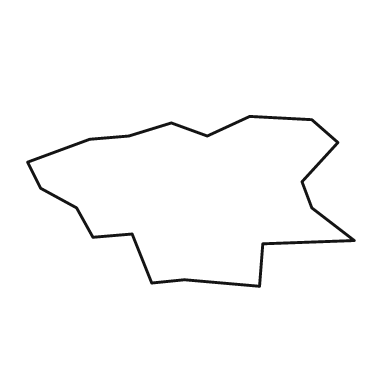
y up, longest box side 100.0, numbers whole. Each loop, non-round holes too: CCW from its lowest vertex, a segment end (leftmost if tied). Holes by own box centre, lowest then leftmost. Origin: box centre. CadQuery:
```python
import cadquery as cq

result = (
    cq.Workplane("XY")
    .moveTo(21.0, -26.0)
    .lineTo(22.0, -13.0)
    .lineTo(50.0, -12.0)
    .lineTo(37.0, -2.0)
    .lineTo(34.0, 6.0)
    .lineTo(45.0, 18.0)
    .lineTo(37.0, 25.0)
    .lineTo(18.0, 26.0)
    .lineTo(5.0, 20.0)
    .lineTo(-6.0, 24.0)
    .lineTo(-19.0, 20.0)
    .lineTo(-31.0, 19.0)
    .lineTo(-50.0, 12.0)
    .lineTo(-46.0, 4.0)
    .lineTo(-35.0, -2.0)
    .lineTo(-30.0, -11.0)
    .lineTo(-18.0, -10.0)
    .lineTo(-12.0, -25.0)
    .lineTo(-2.0, -24.0)
    .close()
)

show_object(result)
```